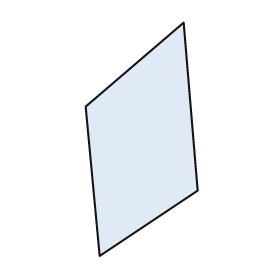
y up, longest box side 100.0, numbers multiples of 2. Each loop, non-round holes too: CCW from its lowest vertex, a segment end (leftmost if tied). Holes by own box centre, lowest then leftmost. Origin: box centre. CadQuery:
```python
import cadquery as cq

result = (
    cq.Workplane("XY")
    .moveTo(-18.0, -50.0)
    .lineTo(24.0, -22.0)
    .lineTo(18.0, 50.0)
    .lineTo(-24.0, 14.0)
    .close()
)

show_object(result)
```